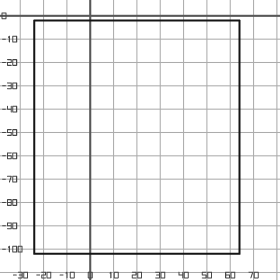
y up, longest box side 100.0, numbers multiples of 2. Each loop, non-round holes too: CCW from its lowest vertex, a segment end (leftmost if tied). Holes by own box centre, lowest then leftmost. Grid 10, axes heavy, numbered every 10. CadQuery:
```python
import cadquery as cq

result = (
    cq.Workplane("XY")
    .moveTo(-24.0, -102.0)
    .lineTo(64.0, -102.0)
    .lineTo(64.0, -2.0)
    .lineTo(-24.0, -2.0)
    .close()
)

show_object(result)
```